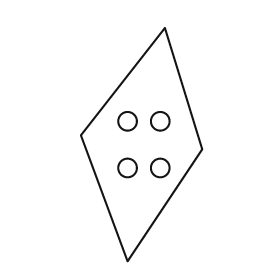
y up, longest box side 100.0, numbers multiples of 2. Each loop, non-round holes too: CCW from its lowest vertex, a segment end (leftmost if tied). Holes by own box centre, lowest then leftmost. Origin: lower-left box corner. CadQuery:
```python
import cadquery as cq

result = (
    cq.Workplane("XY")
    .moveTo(20.0, 0.0)
    .lineTo(52.0, 48.0)
    .lineTo(36.0, 100.0)
    .lineTo(0.0, 54.0)
    .close()
    .moveTo(20.0, 40.0)
    .circle(4.0)
    .moveTo(34.0, 40.0)
    .circle(4.0)
    .moveTo(20.0, 60.0)
    .circle(4.0)
    .moveTo(34.0, 60.0)
    .circle(4.0)
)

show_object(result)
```